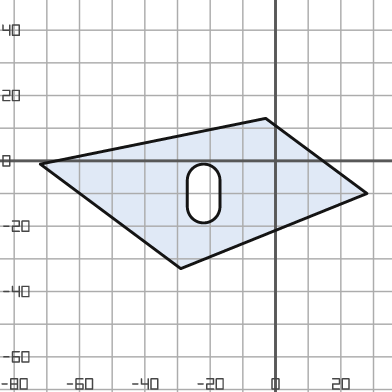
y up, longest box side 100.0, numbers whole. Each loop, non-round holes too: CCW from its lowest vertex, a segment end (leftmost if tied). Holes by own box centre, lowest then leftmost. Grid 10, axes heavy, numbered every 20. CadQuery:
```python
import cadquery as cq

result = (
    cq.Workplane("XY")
    .moveTo(-29.0, -33.0)
    .lineTo(28.0, -10.0)
    .lineTo(-3.0, 13.0)
    .lineTo(-72.0, -1.0)
    .close()
    .moveTo(-27.0, -14.0)
    .threePointArc((-22.0, -19.0), (-17.0, -14.0))
    .lineTo(-17.0, -6.0)
    .threePointArc((-22.0, -1.0), (-27.0, -6.0))
    .close()
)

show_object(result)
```